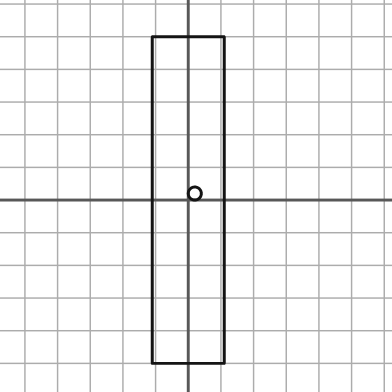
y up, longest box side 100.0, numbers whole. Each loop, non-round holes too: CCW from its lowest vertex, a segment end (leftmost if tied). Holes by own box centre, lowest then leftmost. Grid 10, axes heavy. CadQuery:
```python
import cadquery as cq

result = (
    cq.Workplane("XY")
    .moveTo(-11.0, -50.0)
    .lineTo(11.0, -50.0)
    .lineTo(11.0, 50.0)
    .lineTo(-11.0, 50.0)
    .close()
    .moveTo(2.0, 2.0)
    .circle(2.0)
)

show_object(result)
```